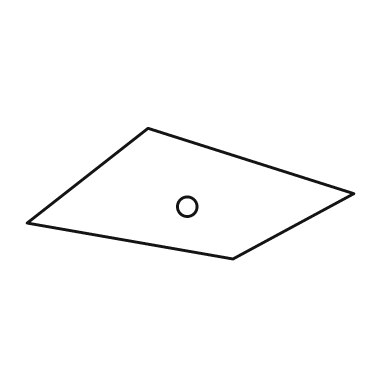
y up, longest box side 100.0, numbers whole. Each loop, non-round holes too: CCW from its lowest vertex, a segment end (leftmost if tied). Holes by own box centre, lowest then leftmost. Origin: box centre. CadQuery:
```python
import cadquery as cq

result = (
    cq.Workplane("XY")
    .moveTo(13.0, -20.0)
    .lineTo(50.0, 0.0)
    .lineTo(-13.0, 20.0)
    .lineTo(-50.0, -9.0)
    .close()
    .moveTo(-1.0, -4.0)
    .circle(3.0)
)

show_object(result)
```